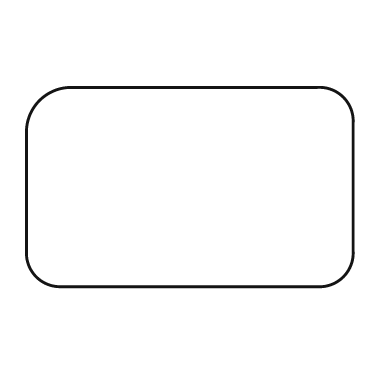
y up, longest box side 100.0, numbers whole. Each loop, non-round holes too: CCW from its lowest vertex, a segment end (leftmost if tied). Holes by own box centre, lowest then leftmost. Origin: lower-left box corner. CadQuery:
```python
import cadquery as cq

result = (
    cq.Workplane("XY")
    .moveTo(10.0, 0.0)
    .lineTo(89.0, 0.0)
    .threePointArc((97.0, 3.0), (100.0, 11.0))
    .lineTo(100.0, 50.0)
    .threePointArc((97.0, 58.0), (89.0, 61.0))
    .lineTo(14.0, 61.0)
    .threePointArc((4.0, 57.0), (0.0, 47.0))
    .lineTo(0.0, 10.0)
    .threePointArc((3.0, 3.0), (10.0, 0.0))
    .close()
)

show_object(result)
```